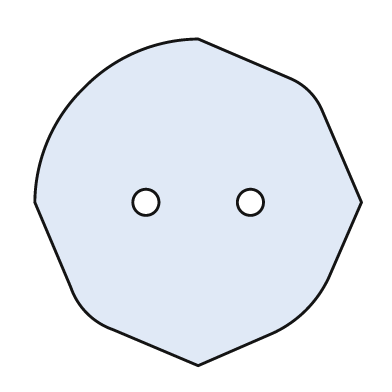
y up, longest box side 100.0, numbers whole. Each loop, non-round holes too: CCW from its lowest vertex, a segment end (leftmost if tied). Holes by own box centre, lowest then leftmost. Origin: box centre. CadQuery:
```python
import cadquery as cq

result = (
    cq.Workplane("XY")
    .moveTo(0.0, -50.0)
    .lineTo(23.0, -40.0)
    .threePointArc((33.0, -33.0), (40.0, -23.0))
    .lineTo(50.0, 0.0)
    .lineTo(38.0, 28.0)
    .threePointArc((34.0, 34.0), (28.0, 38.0))
    .lineTo(0.0, 50.0)
    .threePointArc((-19.0, 46.0), (-35.0, 35.0))
    .threePointArc((-46.0, 19.0), (-50.0, 0.0))
    .lineTo(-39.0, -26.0)
    .threePointArc((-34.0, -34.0), (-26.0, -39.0))
    .close()
    .moveTo(-16.0, 0.0)
    .circle(4.0)
    .moveTo(16.0, 0.0)
    .circle(4.0)
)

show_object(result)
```